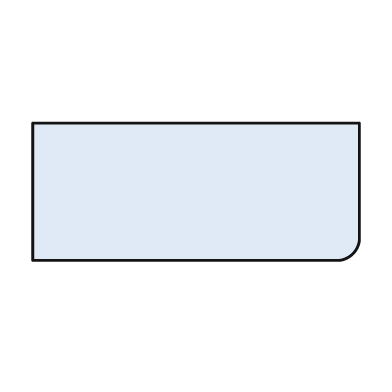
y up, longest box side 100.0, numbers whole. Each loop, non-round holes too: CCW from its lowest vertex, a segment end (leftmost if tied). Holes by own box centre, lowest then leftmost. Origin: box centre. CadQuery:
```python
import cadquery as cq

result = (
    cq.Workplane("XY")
    .moveTo(-50.0, -21.0)
    .lineTo(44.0, -21.0)
    .threePointArc((48.0, -19.0), (50.0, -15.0))
    .lineTo(50.0, 21.0)
    .lineTo(-50.0, 21.0)
    .close()
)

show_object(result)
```